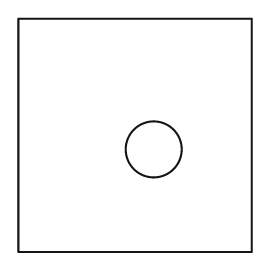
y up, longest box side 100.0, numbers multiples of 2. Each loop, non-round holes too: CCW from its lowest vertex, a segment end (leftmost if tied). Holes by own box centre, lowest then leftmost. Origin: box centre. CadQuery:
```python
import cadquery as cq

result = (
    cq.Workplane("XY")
    .moveTo(-50.0, -50.0)
    .lineTo(50.0, -50.0)
    .lineTo(50.0, 50.0)
    .lineTo(-50.0, 50.0)
    .close()
    .moveTo(8.0, -6.0)
    .circle(12.0)
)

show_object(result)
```